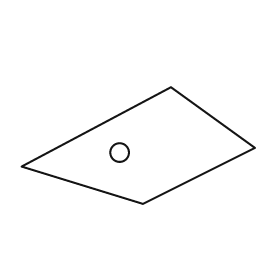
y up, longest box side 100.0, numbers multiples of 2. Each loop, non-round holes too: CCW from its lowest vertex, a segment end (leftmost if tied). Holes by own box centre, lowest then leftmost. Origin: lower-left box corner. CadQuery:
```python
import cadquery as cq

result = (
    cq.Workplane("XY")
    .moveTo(52.0, 0.0)
    .lineTo(100.0, 24.0)
    .lineTo(64.0, 50.0)
    .lineTo(0.0, 16.0)
    .close()
    .moveTo(42.0, 22.0)
    .circle(4.0)
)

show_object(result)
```